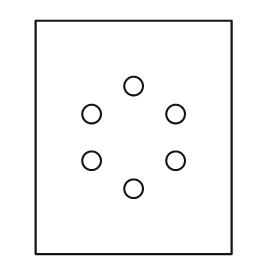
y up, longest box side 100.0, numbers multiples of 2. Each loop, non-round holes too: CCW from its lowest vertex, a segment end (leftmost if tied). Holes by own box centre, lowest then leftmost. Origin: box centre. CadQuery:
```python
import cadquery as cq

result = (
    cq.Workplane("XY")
    .moveTo(-42.0, -50.0)
    .lineTo(42.0, -50.0)
    .lineTo(42.0, 50.0)
    .lineTo(-42.0, 50.0)
    .close()
    .moveTo(0.0, -22.0)
    .circle(4.0)
    .moveTo(-18.0, -10.0)
    .circle(4.0)
    .moveTo(18.0, -10.0)
    .circle(4.0)
    .moveTo(-18.0, 10.0)
    .circle(4.0)
    .moveTo(18.0, 10.0)
    .circle(4.0)
    .moveTo(0.0, 22.0)
    .circle(4.0)
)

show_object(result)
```